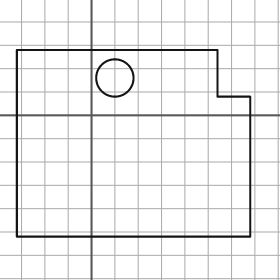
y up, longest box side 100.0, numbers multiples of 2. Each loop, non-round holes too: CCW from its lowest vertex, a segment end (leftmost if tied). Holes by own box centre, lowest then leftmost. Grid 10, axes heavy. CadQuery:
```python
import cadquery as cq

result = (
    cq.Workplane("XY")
    .moveTo(-32.0, -52.0)
    .lineTo(68.0, -52.0)
    .lineTo(68.0, 8.0)
    .lineTo(54.0, 8.0)
    .lineTo(54.0, 28.0)
    .lineTo(-32.0, 28.0)
    .close()
    .moveTo(10.0, 16.0)
    .circle(8.0)
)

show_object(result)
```